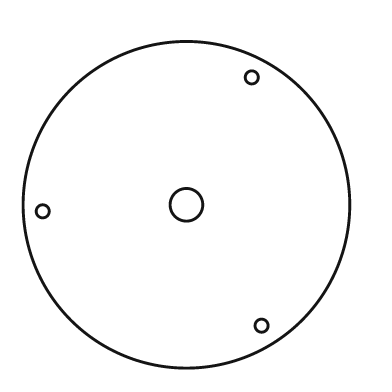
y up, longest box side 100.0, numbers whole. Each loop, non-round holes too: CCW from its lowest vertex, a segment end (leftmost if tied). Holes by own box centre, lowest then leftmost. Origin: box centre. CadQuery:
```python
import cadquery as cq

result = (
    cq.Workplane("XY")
    .moveTo(0.0, 0.0)
    .circle(50.0)
    .moveTo(23.0, -37.0)
    .circle(2.0)
    .moveTo(-44.0, -2.0)
    .circle(2.0)
    .moveTo(0.0, 0.0)
    .circle(5.0)
    .moveTo(20.0, 39.0)
    .circle(2.0)
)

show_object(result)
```